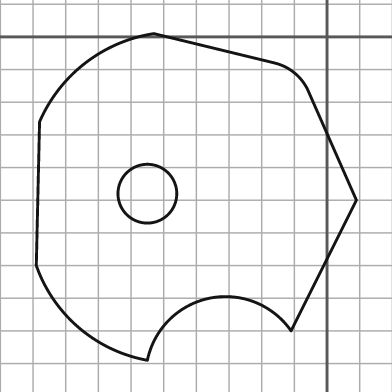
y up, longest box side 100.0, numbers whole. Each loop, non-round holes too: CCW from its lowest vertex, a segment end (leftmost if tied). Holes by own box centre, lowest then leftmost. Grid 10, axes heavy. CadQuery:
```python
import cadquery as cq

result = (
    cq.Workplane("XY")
    .moveTo(-55.0, -99.0)
    .threePointArc((-36.0, -80.0), (-11.0, -90.0))
    .lineTo(9.0, -50.0)
    .lineTo(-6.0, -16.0)
    .threePointArc((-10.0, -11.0), (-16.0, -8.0))
    .lineTo(-53.0, 1.0)
    .threePointArc((-74.0, -8.0), (-88.0, -26.0))
    .lineTo(-89.0, -70.0)
    .threePointArc((-76.0, -89.0), (-55.0, -99.0))
    .close()
    .moveTo(-55.0, -48.0)
    .circle(9.0)
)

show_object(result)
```